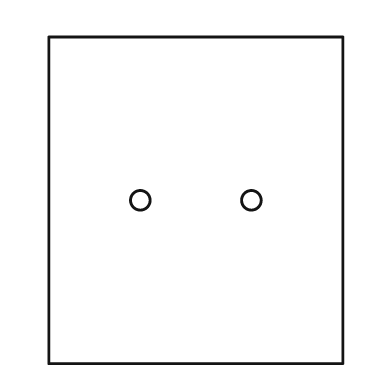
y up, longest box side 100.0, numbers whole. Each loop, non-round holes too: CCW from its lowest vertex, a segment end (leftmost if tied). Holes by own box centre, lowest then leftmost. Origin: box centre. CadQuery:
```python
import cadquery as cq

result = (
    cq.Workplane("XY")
    .moveTo(-45.0, -50.0)
    .lineTo(45.0, -50.0)
    .lineTo(45.0, 50.0)
    .lineTo(-45.0, 50.0)
    .close()
    .moveTo(-17.0, 0.0)
    .circle(3.0)
    .moveTo(17.0, 0.0)
    .circle(3.0)
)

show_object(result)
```